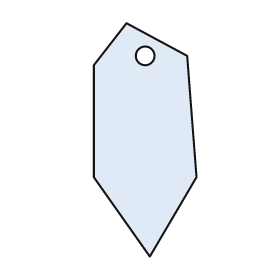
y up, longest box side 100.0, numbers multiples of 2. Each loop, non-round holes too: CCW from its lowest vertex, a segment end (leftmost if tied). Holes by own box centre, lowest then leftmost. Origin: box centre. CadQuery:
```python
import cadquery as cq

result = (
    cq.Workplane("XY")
    .moveTo(2.0, -50.0)
    .lineTo(22.0, -16.0)
    .lineTo(18.0, 36.0)
    .lineTo(-8.0, 50.0)
    .lineTo(-22.0, 32.0)
    .lineTo(-22.0, -16.0)
    .close()
    .moveTo(0.0, 36.0)
    .circle(4.0)
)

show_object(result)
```